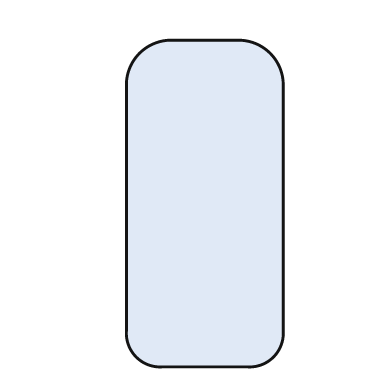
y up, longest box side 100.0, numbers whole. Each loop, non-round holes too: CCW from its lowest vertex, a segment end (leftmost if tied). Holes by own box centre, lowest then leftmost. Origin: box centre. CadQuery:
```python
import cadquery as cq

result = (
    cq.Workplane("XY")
    .moveTo(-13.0, -50.0)
    .lineTo(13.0, -50.0)
    .threePointArc((21.0, -47.0), (24.0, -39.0))
    .lineTo(24.0, 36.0)
    .threePointArc((20.0, 46.0), (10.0, 50.0))
    .lineTo(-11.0, 50.0)
    .threePointArc((-20.0, 46.0), (-24.0, 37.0))
    .lineTo(-24.0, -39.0)
    .threePointArc((-21.0, -47.0), (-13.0, -50.0))
    .close()
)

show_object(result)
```